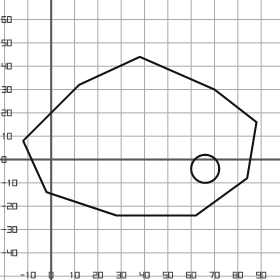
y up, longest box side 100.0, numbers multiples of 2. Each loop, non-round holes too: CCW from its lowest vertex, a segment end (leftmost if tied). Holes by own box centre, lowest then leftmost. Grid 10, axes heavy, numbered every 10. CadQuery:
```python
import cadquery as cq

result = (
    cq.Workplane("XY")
    .moveTo(28.0, -24.0)
    .lineTo(62.0, -24.0)
    .lineTo(84.0, -8.0)
    .lineTo(88.0, 16.0)
    .lineTo(70.0, 30.0)
    .lineTo(38.0, 44.0)
    .lineTo(12.0, 32.0)
    .lineTo(-12.0, 8.0)
    .lineTo(-2.0, -14.0)
    .close()
    .moveTo(66.0, -4.0)
    .circle(6.0)
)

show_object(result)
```